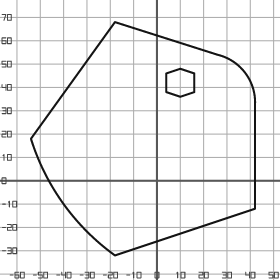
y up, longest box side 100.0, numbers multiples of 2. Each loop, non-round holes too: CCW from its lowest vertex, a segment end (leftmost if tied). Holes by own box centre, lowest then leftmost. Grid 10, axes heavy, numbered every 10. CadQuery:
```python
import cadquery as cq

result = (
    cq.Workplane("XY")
    .moveTo(-18.0, -32.0)
    .lineTo(42.0, -12.0)
    .lineTo(42.0, 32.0)
    .threePointArc((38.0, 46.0), (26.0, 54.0))
    .lineTo(-18.0, 68.0)
    .lineTo(-54.0, 18.0)
    .threePointArc((-40.0, -10.0), (-18.0, -32.0))
    .close()
    .moveTo(10.0, 36.0)
    .lineTo(16.0, 38.0)
    .lineTo(16.0, 46.0)
    .lineTo(10.0, 48.0)
    .lineTo(4.0, 46.0)
    .lineTo(4.0, 38.0)
    .close()
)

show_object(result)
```